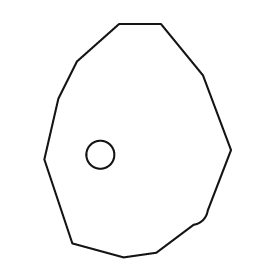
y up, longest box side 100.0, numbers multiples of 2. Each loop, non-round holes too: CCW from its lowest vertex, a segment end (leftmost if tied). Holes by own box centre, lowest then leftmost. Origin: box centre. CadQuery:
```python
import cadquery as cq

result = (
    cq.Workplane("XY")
    .moveTo(-6.0, -50.0)
    .lineTo(8.0, -48.0)
    .lineTo(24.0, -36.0)
    .threePointArc((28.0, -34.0), (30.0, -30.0))
    .lineTo(40.0, -4.0)
    .lineTo(28.0, 28.0)
    .lineTo(10.0, 50.0)
    .lineTo(-8.0, 50.0)
    .lineTo(-26.0, 34.0)
    .lineTo(-34.0, 18.0)
    .lineTo(-40.0, -8.0)
    .lineTo(-28.0, -44.0)
    .close()
    .moveTo(-16.0, -6.0)
    .circle(6.0)
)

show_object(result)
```